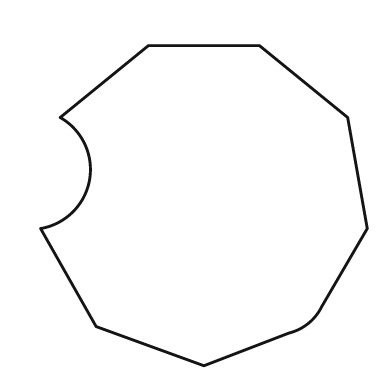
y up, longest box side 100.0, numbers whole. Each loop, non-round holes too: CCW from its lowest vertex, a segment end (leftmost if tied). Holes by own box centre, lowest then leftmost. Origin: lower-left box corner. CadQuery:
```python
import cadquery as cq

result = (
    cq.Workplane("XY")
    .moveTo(50.0, 0.0)
    .lineTo(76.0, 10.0)
    .threePointArc((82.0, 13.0), (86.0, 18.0))
    .lineTo(100.0, 42.0)
    .lineTo(94.0, 76.0)
    .lineTo(67.0, 98.0)
    .lineTo(33.0, 98.0)
    .lineTo(6.0, 76.0)
    .threePointArc((15.0, 57.0), (0.0, 42.0))
    .lineTo(17.0, 12.0)
    .close()
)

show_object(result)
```